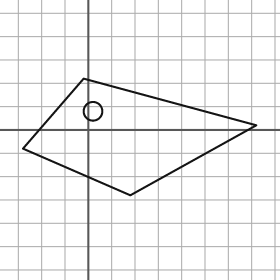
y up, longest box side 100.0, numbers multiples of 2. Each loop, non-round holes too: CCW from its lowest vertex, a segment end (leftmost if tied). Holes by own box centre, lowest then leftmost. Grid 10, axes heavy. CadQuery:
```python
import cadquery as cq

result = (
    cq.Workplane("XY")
    .moveTo(18.0, -28.0)
    .lineTo(72.0, 2.0)
    .lineTo(-2.0, 22.0)
    .lineTo(-28.0, -8.0)
    .close()
    .moveTo(2.0, 8.0)
    .circle(4.0)
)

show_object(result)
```